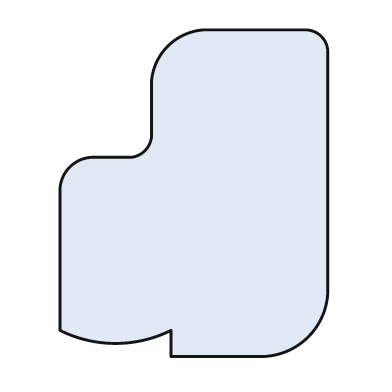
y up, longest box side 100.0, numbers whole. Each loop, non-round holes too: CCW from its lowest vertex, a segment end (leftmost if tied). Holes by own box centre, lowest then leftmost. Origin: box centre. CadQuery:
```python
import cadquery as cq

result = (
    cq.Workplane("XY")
    .moveTo(-7.0, -50.0)
    .lineTo(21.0, -50.0)
    .threePointArc((35.0, -44.0), (41.0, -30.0))
    .lineTo(41.0, 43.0)
    .threePointArc((39.0, 48.0), (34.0, 50.0))
    .lineTo(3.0, 50.0)
    .threePointArc((-8.0, 45.0), (-13.0, 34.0))
    .lineTo(-13.0, 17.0)
    .threePointArc((-15.0, 13.0), (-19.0, 11.0))
    .lineTo(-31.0, 11.0)
    .threePointArc((-38.0, 8.0), (-41.0, 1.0))
    .lineTo(-41.0, -42.0)
    .threePointArc((-24.0, -46.0), (-7.0, -42.0))
    .close()
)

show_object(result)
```